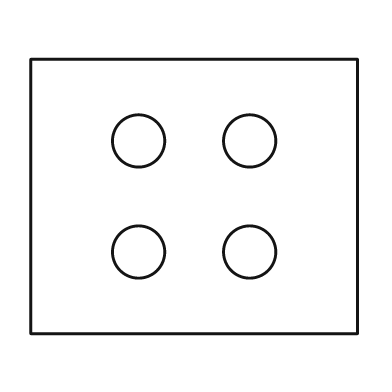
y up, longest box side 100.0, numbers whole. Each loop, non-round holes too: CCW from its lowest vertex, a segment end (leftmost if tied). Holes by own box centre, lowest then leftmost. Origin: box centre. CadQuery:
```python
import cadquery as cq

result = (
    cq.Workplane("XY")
    .moveTo(-50.0, -42.0)
    .lineTo(50.0, -42.0)
    .lineTo(50.0, 42.0)
    .lineTo(-50.0, 42.0)
    .close()
    .moveTo(-17.0, -17.0)
    .circle(8.0)
    .moveTo(17.0, -17.0)
    .circle(8.0)
    .moveTo(-17.0, 17.0)
    .circle(8.0)
    .moveTo(17.0, 17.0)
    .circle(8.0)
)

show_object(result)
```